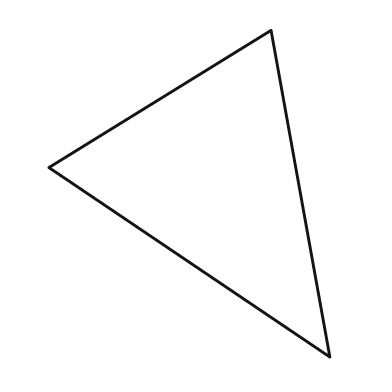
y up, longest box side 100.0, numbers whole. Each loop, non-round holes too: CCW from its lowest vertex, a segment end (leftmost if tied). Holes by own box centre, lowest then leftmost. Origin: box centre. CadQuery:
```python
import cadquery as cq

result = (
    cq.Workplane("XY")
    .moveTo(43.0, -50.0)
    .lineTo(25.0, 50.0)
    .lineTo(-43.0, 8.0)
    .close()
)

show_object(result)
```